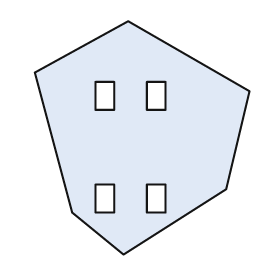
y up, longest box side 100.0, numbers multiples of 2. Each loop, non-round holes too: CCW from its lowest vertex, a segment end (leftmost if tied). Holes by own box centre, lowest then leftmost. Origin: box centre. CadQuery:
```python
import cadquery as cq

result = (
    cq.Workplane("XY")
    .moveTo(-8.0, -50.0)
    .lineTo(36.0, -22.0)
    .lineTo(46.0, 20.0)
    .lineTo(-6.0, 50.0)
    .lineTo(-46.0, 28.0)
    .lineTo(-30.0, -32.0)
    .close()
    .moveTo(-20.0, -32.0)
    .lineTo(-12.0, -32.0)
    .lineTo(-12.0, -20.0)
    .lineTo(-20.0, -20.0)
    .close()
    .moveTo(2.0, -32.0)
    .lineTo(10.0, -32.0)
    .lineTo(10.0, -20.0)
    .lineTo(2.0, -20.0)
    .close()
    .moveTo(-20.0, 12.0)
    .lineTo(-12.0, 12.0)
    .lineTo(-12.0, 24.0)
    .lineTo(-20.0, 24.0)
    .close()
    .moveTo(2.0, 12.0)
    .lineTo(10.0, 12.0)
    .lineTo(10.0, 24.0)
    .lineTo(2.0, 24.0)
    .close()
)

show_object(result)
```